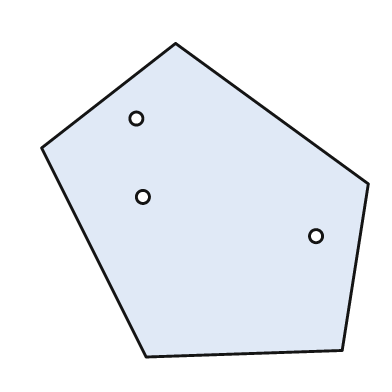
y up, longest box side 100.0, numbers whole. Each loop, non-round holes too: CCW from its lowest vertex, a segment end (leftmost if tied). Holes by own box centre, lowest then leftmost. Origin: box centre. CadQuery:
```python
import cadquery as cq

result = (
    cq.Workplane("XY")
    .moveTo(-18.0, -48.0)
    .lineTo(42.0, -46.0)
    .lineTo(50.0, 5.0)
    .lineTo(-9.0, 48.0)
    .lineTo(-50.0, 16.0)
    .close()
    .moveTo(34.0, -11.0)
    .circle(2.0)
    .moveTo(-19.0, 1.0)
    .circle(2.0)
    .moveTo(-21.0, 25.0)
    .circle(2.0)
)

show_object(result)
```